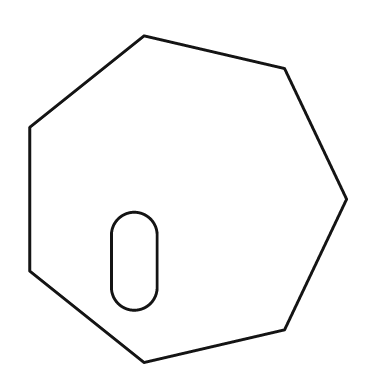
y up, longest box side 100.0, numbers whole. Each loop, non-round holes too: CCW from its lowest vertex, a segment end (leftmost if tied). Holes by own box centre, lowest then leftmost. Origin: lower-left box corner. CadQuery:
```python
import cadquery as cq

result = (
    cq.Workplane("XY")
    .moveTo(35.0, 0.0)
    .lineTo(78.0, 10.0)
    .lineTo(97.0, 50.0)
    .lineTo(78.0, 90.0)
    .lineTo(35.0, 100.0)
    .lineTo(0.0, 72.0)
    .lineTo(0.0, 28.0)
    .close()
    .moveTo(25.0, 23.0)
    .threePointArc((32.0, 16.0), (39.0, 23.0))
    .lineTo(39.0, 39.0)
    .threePointArc((32.0, 46.0), (25.0, 39.0))
    .close()
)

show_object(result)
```